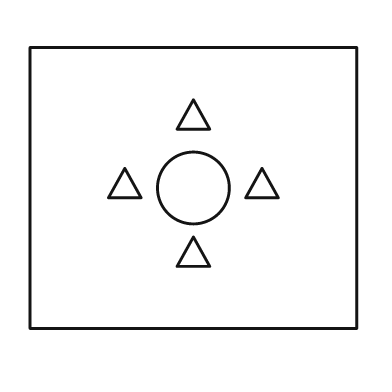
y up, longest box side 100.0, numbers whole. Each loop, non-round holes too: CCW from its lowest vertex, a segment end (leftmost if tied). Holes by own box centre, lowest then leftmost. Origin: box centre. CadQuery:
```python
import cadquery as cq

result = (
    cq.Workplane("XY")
    .moveTo(-50.0, -43.0)
    .lineTo(50.0, -43.0)
    .lineTo(50.0, 43.0)
    .lineTo(-50.0, 43.0)
    .close()
    .moveTo(-5.0, -24.0)
    .lineTo(5.0, -24.0)
    .lineTo(0.0, -15.0)
    .close()
    .moveTo(0.0, 0.0)
    .circle(11.0)
    .moveTo(-26.0, -3.0)
    .lineTo(-16.0, -3.0)
    .lineTo(-21.0, 6.0)
    .close()
    .moveTo(16.0, -3.0)
    .lineTo(26.0, -3.0)
    .lineTo(21.0, 6.0)
    .close()
    .moveTo(-5.0, 18.0)
    .lineTo(5.0, 18.0)
    .lineTo(0.0, 27.0)
    .close()
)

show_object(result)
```